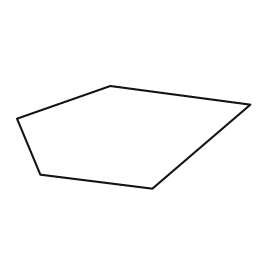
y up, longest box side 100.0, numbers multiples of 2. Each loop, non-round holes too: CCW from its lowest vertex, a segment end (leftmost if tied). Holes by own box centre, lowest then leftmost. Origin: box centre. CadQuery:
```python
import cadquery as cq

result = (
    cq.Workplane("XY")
    .moveTo(8.0, -22.0)
    .lineTo(50.0, 14.0)
    .lineTo(-10.0, 22.0)
    .lineTo(-50.0, 8.0)
    .lineTo(-40.0, -16.0)
    .close()
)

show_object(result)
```